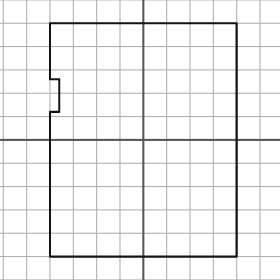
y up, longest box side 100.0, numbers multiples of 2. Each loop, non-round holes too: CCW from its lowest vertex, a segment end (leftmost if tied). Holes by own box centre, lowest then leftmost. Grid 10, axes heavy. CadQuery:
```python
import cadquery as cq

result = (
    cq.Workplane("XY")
    .moveTo(-40.0, -50.0)
    .lineTo(40.0, -50.0)
    .lineTo(40.0, 50.0)
    .lineTo(-40.0, 50.0)
    .lineTo(-40.0, 26.0)
    .lineTo(-36.0, 26.0)
    .lineTo(-36.0, 12.0)
    .lineTo(-40.0, 12.0)
    .close()
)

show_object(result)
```